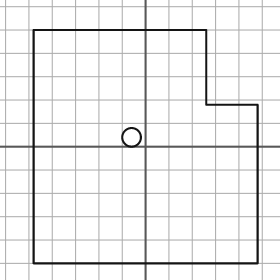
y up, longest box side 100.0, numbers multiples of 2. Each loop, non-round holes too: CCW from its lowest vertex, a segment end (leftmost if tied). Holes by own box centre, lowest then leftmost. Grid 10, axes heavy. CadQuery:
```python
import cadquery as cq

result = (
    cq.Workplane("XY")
    .moveTo(-48.0, -50.0)
    .lineTo(48.0, -50.0)
    .lineTo(48.0, 18.0)
    .lineTo(26.0, 18.0)
    .lineTo(26.0, 50.0)
    .lineTo(-48.0, 50.0)
    .close()
    .moveTo(-6.0, 4.0)
    .circle(4.0)
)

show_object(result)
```